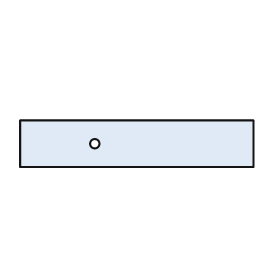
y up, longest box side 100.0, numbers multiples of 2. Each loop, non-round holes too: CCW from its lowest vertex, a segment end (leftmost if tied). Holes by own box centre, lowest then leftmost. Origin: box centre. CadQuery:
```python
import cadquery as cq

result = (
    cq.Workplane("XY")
    .moveTo(-50.0, -10.0)
    .lineTo(50.0, -10.0)
    .lineTo(50.0, 10.0)
    .lineTo(-50.0, 10.0)
    .close()
    .moveTo(-18.0, 0.0)
    .circle(2.0)
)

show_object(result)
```